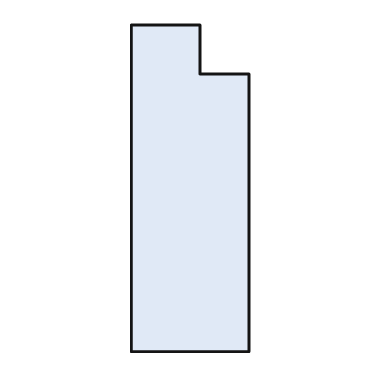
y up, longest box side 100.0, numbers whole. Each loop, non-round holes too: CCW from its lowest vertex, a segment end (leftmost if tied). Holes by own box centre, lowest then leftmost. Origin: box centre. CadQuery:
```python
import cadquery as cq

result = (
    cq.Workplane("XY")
    .moveTo(-18.0, -50.0)
    .lineTo(18.0, -50.0)
    .lineTo(18.0, 35.0)
    .lineTo(3.0, 35.0)
    .lineTo(3.0, 50.0)
    .lineTo(-18.0, 50.0)
    .close()
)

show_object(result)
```